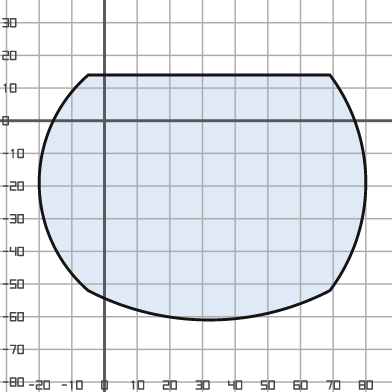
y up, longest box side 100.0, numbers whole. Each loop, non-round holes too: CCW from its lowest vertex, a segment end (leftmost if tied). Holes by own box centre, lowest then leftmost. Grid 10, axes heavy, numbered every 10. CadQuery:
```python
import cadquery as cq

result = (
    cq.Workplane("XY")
    .moveTo(-5.0, -52.0)
    .threePointArc((32.0, -61.0), (69.0, -52.0))
    .threePointArc((80.0, -19.0), (69.0, 14.0))
    .lineTo(-5.0, 14.0)
    .threePointArc((-20.0, -19.0), (-5.0, -52.0))
    .close()
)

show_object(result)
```